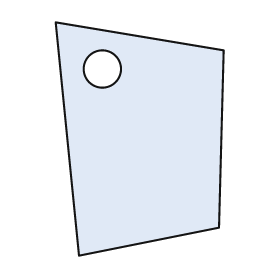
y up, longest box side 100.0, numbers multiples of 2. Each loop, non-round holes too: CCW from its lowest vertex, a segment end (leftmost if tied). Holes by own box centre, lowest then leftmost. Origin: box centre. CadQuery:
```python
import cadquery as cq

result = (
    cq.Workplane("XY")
    .moveTo(-26.0, -50.0)
    .lineTo(34.0, -38.0)
    .lineTo(36.0, 38.0)
    .lineTo(-36.0, 50.0)
    .close()
    .moveTo(-16.0, 30.0)
    .circle(8.0)
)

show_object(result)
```